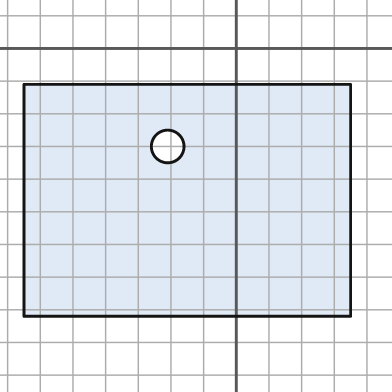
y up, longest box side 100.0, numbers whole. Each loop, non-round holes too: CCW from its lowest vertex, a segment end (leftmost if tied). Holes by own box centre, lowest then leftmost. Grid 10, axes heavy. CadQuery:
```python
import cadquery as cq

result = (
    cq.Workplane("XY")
    .moveTo(-65.0, -82.0)
    .lineTo(35.0, -82.0)
    .lineTo(35.0, -11.0)
    .lineTo(-65.0, -11.0)
    .close()
    .moveTo(-21.0, -30.0)
    .circle(5.0)
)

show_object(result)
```